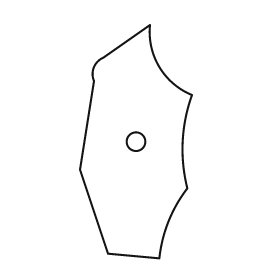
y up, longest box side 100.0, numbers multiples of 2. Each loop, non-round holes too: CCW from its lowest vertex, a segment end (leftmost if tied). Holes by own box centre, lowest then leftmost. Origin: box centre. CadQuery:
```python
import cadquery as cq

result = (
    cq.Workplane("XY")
    .moveTo(10.0, -50.0)
    .threePointArc((14.0, -34.0), (22.0, -20.0))
    .threePointArc((20.0, 0.0), (24.0, 20.0))
    .threePointArc((10.0, 32.0), (6.0, 50.0))
    .lineTo(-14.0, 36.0)
    .threePointArc((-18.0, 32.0), (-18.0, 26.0))
    .lineTo(-24.0, -12.0)
    .lineTo(-12.0, -48.0)
    .close()
    .moveTo(0.0, 0.0)
    .circle(4.0)
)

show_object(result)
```